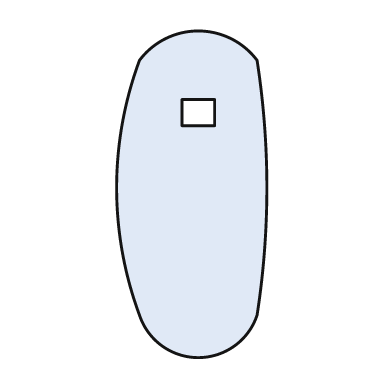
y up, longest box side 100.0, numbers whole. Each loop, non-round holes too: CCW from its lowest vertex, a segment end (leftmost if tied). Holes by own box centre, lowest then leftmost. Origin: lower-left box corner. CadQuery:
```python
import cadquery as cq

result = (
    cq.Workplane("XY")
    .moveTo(7.0, 13.0)
    .threePointArc((25.0, 0.0), (43.0, 13.0))
    .threePointArc((46.0, 52.0), (43.0, 91.0))
    .threePointArc((25.0, 100.0), (7.0, 91.0))
    .threePointArc((0.0, 52.0), (7.0, 13.0))
    .close()
    .moveTo(20.0, 71.0)
    .lineTo(30.0, 71.0)
    .lineTo(30.0, 79.0)
    .lineTo(20.0, 79.0)
    .close()
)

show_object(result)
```